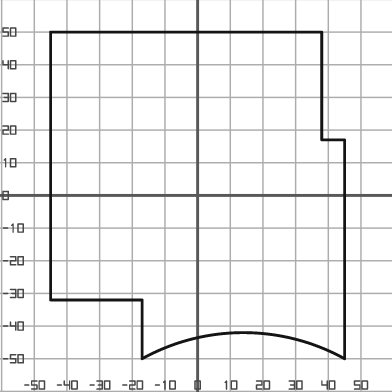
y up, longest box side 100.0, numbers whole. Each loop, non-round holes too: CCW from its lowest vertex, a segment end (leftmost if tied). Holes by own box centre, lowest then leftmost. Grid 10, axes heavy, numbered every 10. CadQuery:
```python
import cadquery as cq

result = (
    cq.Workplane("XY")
    .moveTo(-17.0, -50.0)
    .threePointArc((14.0, -42.0), (45.0, -50.0))
    .lineTo(45.0, 17.0)
    .lineTo(38.0, 17.0)
    .lineTo(38.0, 50.0)
    .lineTo(-45.0, 50.0)
    .lineTo(-45.0, -32.0)
    .lineTo(-17.0, -32.0)
    .close()
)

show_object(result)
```